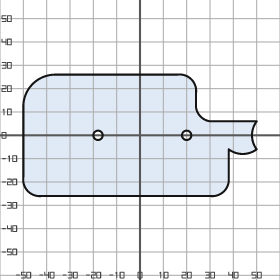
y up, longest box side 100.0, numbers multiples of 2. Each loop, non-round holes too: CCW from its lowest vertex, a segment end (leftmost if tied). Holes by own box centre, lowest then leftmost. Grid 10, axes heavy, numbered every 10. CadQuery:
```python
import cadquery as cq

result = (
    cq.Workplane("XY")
    .moveTo(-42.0, -26.0)
    .lineTo(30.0, -26.0)
    .threePointArc((36.0, -24.0), (38.0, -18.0))
    .lineTo(38.0, -6.0)
    .threePointArc((44.0, -8.0), (50.0, -6.0))
    .threePointArc((48.0, 0.0), (50.0, 6.0))
    .lineTo(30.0, 6.0)
    .threePointArc((26.0, 8.0), (24.0, 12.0))
    .lineTo(24.0, 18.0)
    .threePointArc((22.0, 24.0), (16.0, 26.0))
    .lineTo(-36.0, 26.0)
    .threePointArc((-46.0, 22.0), (-50.0, 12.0))
    .lineTo(-50.0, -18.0)
    .threePointArc((-48.0, -24.0), (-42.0, -26.0))
    .close()
    .moveTo(-18.0, 0.0)
    .circle(2.0)
    .moveTo(20.0, 0.0)
    .circle(2.0)
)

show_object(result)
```